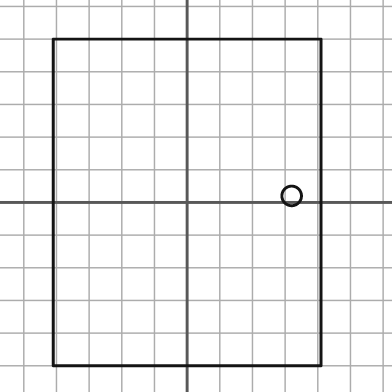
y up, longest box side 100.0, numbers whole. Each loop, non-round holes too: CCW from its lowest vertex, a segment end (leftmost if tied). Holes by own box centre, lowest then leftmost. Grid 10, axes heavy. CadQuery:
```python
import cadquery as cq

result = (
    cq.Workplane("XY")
    .moveTo(-41.0, -50.0)
    .lineTo(41.0, -50.0)
    .lineTo(41.0, 50.0)
    .lineTo(-41.0, 50.0)
    .close()
    .moveTo(32.0, 2.0)
    .circle(3.0)
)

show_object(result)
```